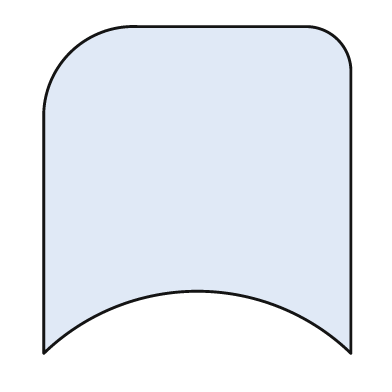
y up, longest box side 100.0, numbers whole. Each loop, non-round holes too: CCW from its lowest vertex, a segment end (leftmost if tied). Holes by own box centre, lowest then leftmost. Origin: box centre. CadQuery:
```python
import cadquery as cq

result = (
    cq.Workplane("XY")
    .moveTo(-47.0, -50.0)
    .threePointArc((0.0, -31.0), (47.0, -50.0))
    .lineTo(47.0, 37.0)
    .threePointArc((43.0, 46.0), (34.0, 50.0))
    .lineTo(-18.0, 50.0)
    .threePointArc((-39.0, 42.0), (-47.0, 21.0))
    .close()
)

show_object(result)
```